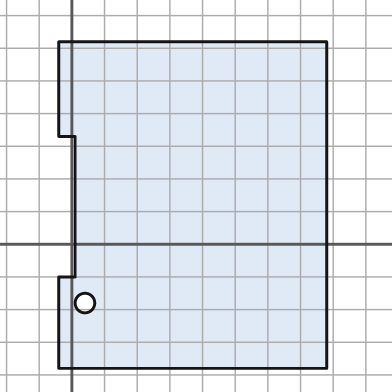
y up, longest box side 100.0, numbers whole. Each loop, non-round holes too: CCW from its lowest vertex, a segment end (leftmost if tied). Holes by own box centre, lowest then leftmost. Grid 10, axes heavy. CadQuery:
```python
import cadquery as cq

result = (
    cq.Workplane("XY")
    .moveTo(-4.0, -38.0)
    .lineTo(78.0, -38.0)
    .lineTo(78.0, 62.0)
    .lineTo(-4.0, 62.0)
    .lineTo(-4.0, 33.0)
    .lineTo(1.0, 33.0)
    .lineTo(1.0, -10.0)
    .lineTo(-4.0, -10.0)
    .close()
    .moveTo(4.0, -18.0)
    .circle(3.0)
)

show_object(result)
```